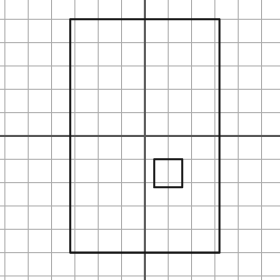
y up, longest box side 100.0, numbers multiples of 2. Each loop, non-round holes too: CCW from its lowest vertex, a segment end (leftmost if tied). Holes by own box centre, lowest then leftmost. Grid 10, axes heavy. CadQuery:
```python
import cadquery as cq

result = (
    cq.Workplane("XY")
    .moveTo(-32.0, -50.0)
    .lineTo(32.0, -50.0)
    .lineTo(32.0, 50.0)
    .lineTo(-32.0, 50.0)
    .close()
    .moveTo(4.0, -22.0)
    .lineTo(16.0, -22.0)
    .lineTo(16.0, -10.0)
    .lineTo(4.0, -10.0)
    .close()
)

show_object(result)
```